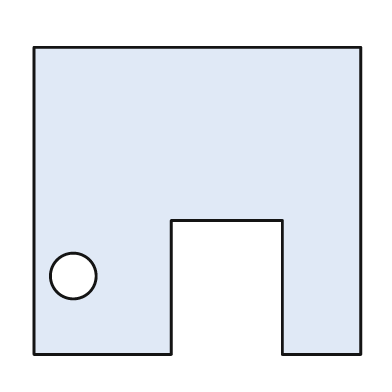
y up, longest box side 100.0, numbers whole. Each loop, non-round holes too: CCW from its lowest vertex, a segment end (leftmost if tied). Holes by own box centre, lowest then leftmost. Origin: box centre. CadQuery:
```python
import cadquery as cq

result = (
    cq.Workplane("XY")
    .moveTo(-50.0, -47.0)
    .lineTo(-8.0, -47.0)
    .lineTo(-8.0, -6.0)
    .lineTo(26.0, -6.0)
    .lineTo(26.0, -47.0)
    .lineTo(50.0, -47.0)
    .lineTo(50.0, 47.0)
    .lineTo(-50.0, 47.0)
    .close()
    .moveTo(-38.0, -23.0)
    .circle(7.0)
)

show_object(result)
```